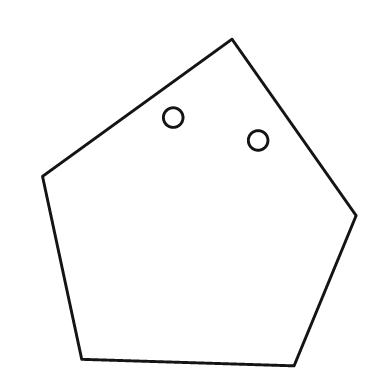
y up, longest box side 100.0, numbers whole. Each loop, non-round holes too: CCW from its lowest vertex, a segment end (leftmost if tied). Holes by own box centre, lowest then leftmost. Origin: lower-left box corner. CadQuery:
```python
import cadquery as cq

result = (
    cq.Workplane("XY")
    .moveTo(77.0, 0.0)
    .lineTo(96.0, 46.0)
    .lineTo(58.0, 100.0)
    .lineTo(0.0, 58.0)
    .lineTo(12.0, 2.0)
    .close()
    .moveTo(66.0, 69.0)
    .circle(3.0)
    .moveTo(40.0, 76.0)
    .circle(3.0)
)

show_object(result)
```